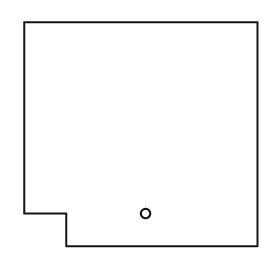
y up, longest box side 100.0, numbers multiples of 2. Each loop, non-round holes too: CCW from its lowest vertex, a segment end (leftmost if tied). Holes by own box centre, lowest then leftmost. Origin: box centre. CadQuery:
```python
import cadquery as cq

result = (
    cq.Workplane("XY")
    .moveTo(-32.0, -48.0)
    .lineTo(50.0, -48.0)
    .lineTo(50.0, 48.0)
    .lineTo(-50.0, 48.0)
    .lineTo(-50.0, -34.0)
    .lineTo(-32.0, -34.0)
    .close()
    .moveTo(2.0, -34.0)
    .circle(2.0)
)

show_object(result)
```